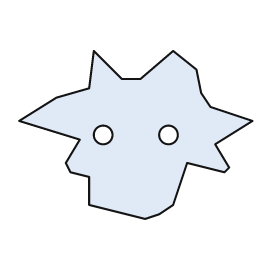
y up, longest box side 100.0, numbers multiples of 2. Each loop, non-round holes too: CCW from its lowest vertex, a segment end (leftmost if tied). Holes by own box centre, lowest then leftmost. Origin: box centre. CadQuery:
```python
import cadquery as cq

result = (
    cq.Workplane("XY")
    .moveTo(4.0, -36.0)
    .lineTo(10.0, -34.0)
    .lineTo(16.0, -30.0)
    .lineTo(22.0, -12.0)
    .lineTo(38.0, -16.0)
    .lineTo(40.0, -14.0)
    .lineTo(34.0, -4.0)
    .lineTo(50.0, 6.0)
    .lineTo(32.0, 12.0)
    .lineTo(28.0, 18.0)
    .lineTo(26.0, 28.0)
    .lineTo(16.0, 36.0)
    .lineTo(2.0, 24.0)
    .lineTo(-6.0, 24.0)
    .lineTo(-18.0, 36.0)
    .lineTo(-20.0, 20.0)
    .lineTo(-34.0, 16.0)
    .lineTo(-50.0, 6.0)
    .lineTo(-24.0, -2.0)
    .lineTo(-30.0, -12.0)
    .lineTo(-28.0, -16.0)
    .lineTo(-20.0, -18.0)
    .lineTo(-20.0, -30.0)
    .close()
    .moveTo(-14.0, 0.0)
    .circle(4.0)
    .moveTo(14.0, 0.0)
    .circle(4.0)
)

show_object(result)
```